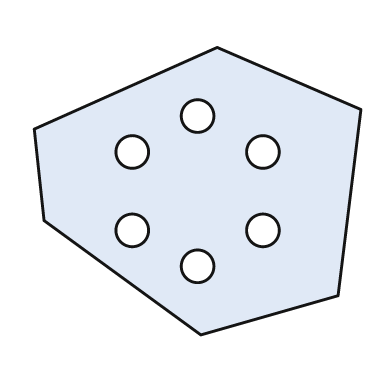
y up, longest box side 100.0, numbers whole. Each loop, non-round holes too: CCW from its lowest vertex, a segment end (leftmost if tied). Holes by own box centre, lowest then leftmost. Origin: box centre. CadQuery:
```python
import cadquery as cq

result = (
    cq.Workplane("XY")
    .moveTo(1.0, -44.0)
    .lineTo(43.0, -32.0)
    .lineTo(50.0, 25.0)
    .lineTo(6.0, 44.0)
    .lineTo(-50.0, 19.0)
    .lineTo(-47.0, -9.0)
    .close()
    .moveTo(0.0, -23.0)
    .circle(5.0)
    .moveTo(-20.0, -12.0)
    .circle(5.0)
    .moveTo(20.0, -12.0)
    .circle(5.0)
    .moveTo(-20.0, 12.0)
    .circle(5.0)
    .moveTo(20.0, 12.0)
    .circle(5.0)
    .moveTo(0.0, 23.0)
    .circle(5.0)
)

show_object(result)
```